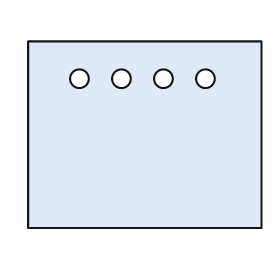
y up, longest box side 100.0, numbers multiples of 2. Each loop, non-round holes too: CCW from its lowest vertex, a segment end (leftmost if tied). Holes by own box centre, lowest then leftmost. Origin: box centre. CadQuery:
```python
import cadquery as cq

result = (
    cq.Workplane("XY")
    .moveTo(-50.0, -40.0)
    .lineTo(50.0, -40.0)
    .lineTo(50.0, 40.0)
    .lineTo(-50.0, 40.0)
    .close()
    .moveTo(-28.0, 24.0)
    .circle(4.0)
    .moveTo(-10.0, 24.0)
    .circle(4.0)
    .moveTo(8.0, 24.0)
    .circle(4.0)
    .moveTo(26.0, 24.0)
    .circle(4.0)
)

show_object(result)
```